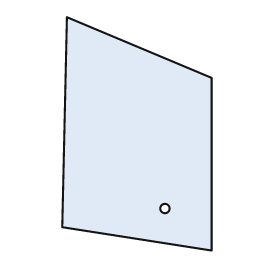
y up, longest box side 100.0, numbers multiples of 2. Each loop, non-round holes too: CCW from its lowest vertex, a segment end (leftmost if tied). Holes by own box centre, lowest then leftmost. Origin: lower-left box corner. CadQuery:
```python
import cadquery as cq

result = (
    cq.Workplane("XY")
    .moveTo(64.0, 0.0)
    .lineTo(64.0, 74.0)
    .lineTo(2.0, 100.0)
    .lineTo(0.0, 10.0)
    .close()
    .moveTo(44.0, 18.0)
    .circle(2.0)
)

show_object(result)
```